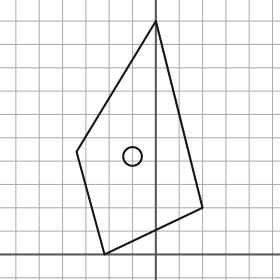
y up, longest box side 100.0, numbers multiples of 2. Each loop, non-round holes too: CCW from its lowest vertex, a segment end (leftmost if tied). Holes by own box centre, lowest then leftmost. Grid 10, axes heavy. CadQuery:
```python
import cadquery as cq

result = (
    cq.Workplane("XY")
    .moveTo(-22.0, 0.0)
    .lineTo(20.0, 20.0)
    .lineTo(0.0, 100.0)
    .lineTo(-34.0, 44.0)
    .close()
    .moveTo(-10.0, 42.0)
    .circle(4.0)
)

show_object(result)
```